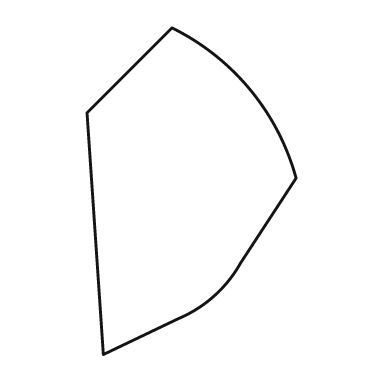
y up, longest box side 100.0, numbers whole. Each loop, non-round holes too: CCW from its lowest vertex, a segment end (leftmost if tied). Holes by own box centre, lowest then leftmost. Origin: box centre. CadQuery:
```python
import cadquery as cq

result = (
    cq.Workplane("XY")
    .moveTo(-27.0, -50.0)
    .lineTo(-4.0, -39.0)
    .threePointArc((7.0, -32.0), (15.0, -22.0))
    .lineTo(32.0, 4.0)
    .threePointArc((18.0, 31.0), (-6.0, 50.0))
    .lineTo(-32.0, 24.0)
    .close()
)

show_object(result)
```